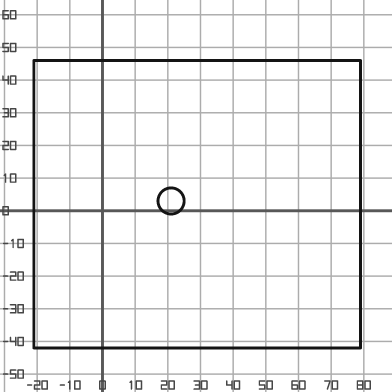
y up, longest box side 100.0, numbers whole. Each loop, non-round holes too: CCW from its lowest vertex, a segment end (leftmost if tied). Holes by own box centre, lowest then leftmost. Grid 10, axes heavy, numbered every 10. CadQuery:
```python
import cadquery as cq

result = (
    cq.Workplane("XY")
    .moveTo(-21.0, -42.0)
    .lineTo(79.0, -42.0)
    .lineTo(79.0, 46.0)
    .lineTo(-21.0, 46.0)
    .close()
    .moveTo(21.0, 3.0)
    .circle(4.0)
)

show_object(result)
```